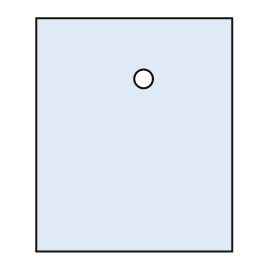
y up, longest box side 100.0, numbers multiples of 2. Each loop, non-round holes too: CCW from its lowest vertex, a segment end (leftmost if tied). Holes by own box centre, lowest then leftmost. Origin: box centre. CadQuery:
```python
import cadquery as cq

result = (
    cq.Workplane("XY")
    .moveTo(-42.0, -50.0)
    .lineTo(42.0, -50.0)
    .lineTo(42.0, 50.0)
    .lineTo(-42.0, 50.0)
    .close()
    .moveTo(4.0, 24.0)
    .circle(4.0)
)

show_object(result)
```